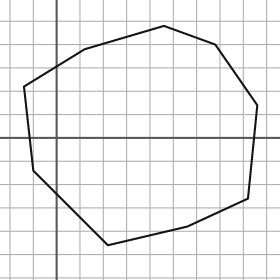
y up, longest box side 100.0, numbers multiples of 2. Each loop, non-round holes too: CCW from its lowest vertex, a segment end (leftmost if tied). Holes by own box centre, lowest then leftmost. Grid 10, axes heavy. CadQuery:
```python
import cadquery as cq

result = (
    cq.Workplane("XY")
    .moveTo(22.0, -46.0)
    .lineTo(56.0, -38.0)
    .lineTo(82.0, -26.0)
    .lineTo(86.0, 14.0)
    .lineTo(68.0, 40.0)
    .lineTo(46.0, 48.0)
    .lineTo(12.0, 38.0)
    .lineTo(-14.0, 22.0)
    .lineTo(-10.0, -14.0)
    .close()
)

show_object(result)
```